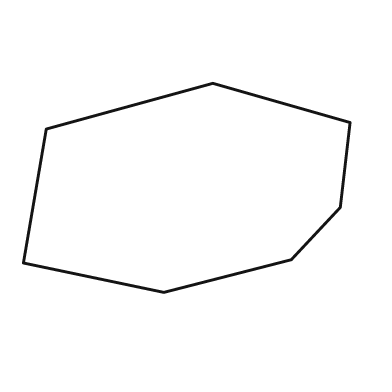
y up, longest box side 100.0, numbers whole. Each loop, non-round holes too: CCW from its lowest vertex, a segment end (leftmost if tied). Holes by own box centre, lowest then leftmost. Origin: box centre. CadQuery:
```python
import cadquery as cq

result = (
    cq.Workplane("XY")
    .moveTo(-7.0, -32.0)
    .lineTo(32.0, -22.0)
    .lineTo(47.0, -6.0)
    .lineTo(50.0, 20.0)
    .lineTo(8.0, 32.0)
    .lineTo(-43.0, 18.0)
    .lineTo(-50.0, -23.0)
    .close()
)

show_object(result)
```